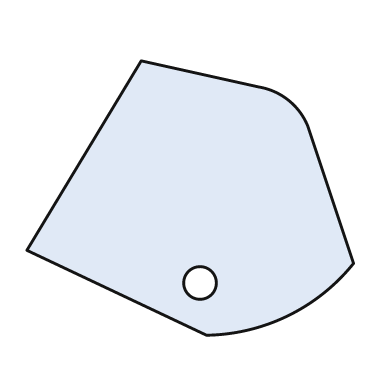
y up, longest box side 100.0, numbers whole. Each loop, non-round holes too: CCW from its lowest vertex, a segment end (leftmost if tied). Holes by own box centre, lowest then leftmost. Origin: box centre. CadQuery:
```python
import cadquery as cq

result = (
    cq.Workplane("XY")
    .moveTo(5.0, -42.0)
    .threePointArc((30.0, -36.0), (50.0, -20.0))
    .lineTo(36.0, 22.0)
    .threePointArc((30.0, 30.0), (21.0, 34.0))
    .lineTo(-15.0, 42.0)
    .lineTo(-50.0, -16.0)
    .close()
    .moveTo(3.0, -26.0)
    .circle(5.0)
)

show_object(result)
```